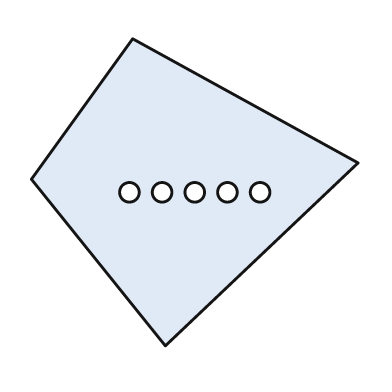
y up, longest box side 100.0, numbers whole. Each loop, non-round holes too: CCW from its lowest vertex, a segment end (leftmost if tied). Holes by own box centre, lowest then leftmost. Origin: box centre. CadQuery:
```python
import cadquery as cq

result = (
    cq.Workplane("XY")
    .moveTo(-9.0, -47.0)
    .lineTo(50.0, 9.0)
    .lineTo(-19.0, 47.0)
    .lineTo(-50.0, 4.0)
    .close()
    .moveTo(-20.0, 0.0)
    .circle(3.0)
    .moveTo(-10.0, 0.0)
    .circle(3.0)
    .moveTo(0.0, 0.0)
    .circle(3.0)
    .moveTo(10.0, 0.0)
    .circle(3.0)
    .moveTo(20.0, 0.0)
    .circle(3.0)
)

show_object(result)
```